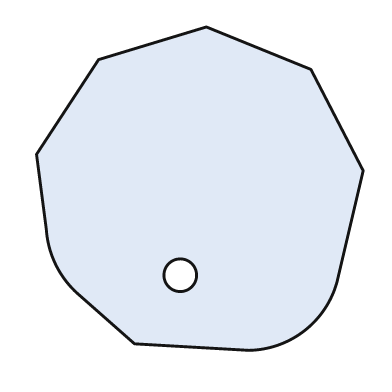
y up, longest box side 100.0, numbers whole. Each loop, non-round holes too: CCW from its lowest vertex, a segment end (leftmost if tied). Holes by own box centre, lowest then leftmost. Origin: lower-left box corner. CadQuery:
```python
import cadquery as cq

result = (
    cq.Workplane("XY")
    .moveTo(65.0, 0.0)
    .threePointArc((82.0, 6.0), (92.0, 21.0))
    .lineTo(100.0, 55.0)
    .lineTo(84.0, 86.0)
    .lineTo(52.0, 99.0)
    .lineTo(19.0, 89.0)
    .lineTo(0.0, 60.0)
    .lineTo(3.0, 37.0)
    .threePointArc((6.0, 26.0), (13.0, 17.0))
    .lineTo(30.0, 2.0)
    .close()
    .moveTo(44.0, 23.0)
    .circle(5.0)
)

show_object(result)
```